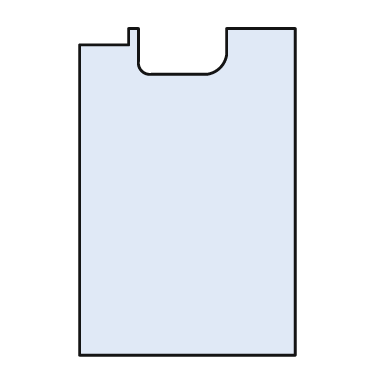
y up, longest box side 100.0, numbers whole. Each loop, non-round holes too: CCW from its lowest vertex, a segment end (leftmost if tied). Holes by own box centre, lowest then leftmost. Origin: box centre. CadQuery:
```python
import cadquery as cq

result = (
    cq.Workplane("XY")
    .moveTo(-33.0, -50.0)
    .lineTo(33.0, -50.0)
    .lineTo(33.0, 50.0)
    .lineTo(12.0, 50.0)
    .lineTo(12.0, 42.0)
    .threePointArc((10.0, 38.0), (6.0, 36.0))
    .lineTo(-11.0, 36.0)
    .threePointArc((-14.0, 37.0), (-15.0, 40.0))
    .lineTo(-15.0, 50.0)
    .lineTo(-18.0, 50.0)
    .lineTo(-18.0, 45.0)
    .lineTo(-33.0, 45.0)
    .close()
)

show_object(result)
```